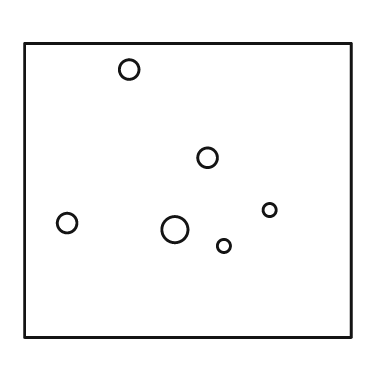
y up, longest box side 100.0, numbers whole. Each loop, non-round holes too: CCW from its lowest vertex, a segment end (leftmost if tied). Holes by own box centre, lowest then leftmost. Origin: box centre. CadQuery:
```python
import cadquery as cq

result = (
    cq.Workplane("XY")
    .moveTo(-50.0, -45.0)
    .lineTo(50.0, -45.0)
    .lineTo(50.0, 45.0)
    .lineTo(-50.0, 45.0)
    .close()
    .moveTo(11.0, -17.0)
    .circle(2.0)
    .moveTo(-4.0, -12.0)
    .circle(4.0)
    .moveTo(-37.0, -10.0)
    .circle(3.0)
    .moveTo(25.0, -6.0)
    .circle(2.0)
    .moveTo(6.0, 10.0)
    .circle(3.0)
    .moveTo(-18.0, 37.0)
    .circle(3.0)
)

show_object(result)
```